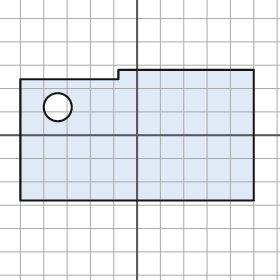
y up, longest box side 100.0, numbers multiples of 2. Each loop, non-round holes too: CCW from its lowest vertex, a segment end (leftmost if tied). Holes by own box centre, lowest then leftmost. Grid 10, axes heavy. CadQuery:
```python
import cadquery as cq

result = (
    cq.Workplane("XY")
    .moveTo(-50.0, -28.0)
    .lineTo(50.0, -28.0)
    .lineTo(50.0, 28.0)
    .lineTo(-8.0, 28.0)
    .lineTo(-8.0, 24.0)
    .lineTo(-50.0, 24.0)
    .close()
    .moveTo(-34.0, 12.0)
    .circle(6.0)
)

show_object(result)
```